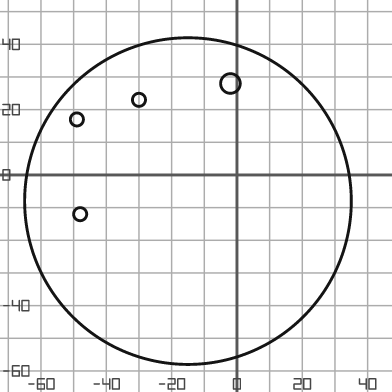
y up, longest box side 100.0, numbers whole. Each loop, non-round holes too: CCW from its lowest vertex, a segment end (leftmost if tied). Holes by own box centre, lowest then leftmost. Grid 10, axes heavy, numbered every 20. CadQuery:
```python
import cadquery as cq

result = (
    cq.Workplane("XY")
    .moveTo(-15.0, -8.0)
    .circle(50.0)
    .moveTo(-48.0, -12.0)
    .circle(2.0)
    .moveTo(-49.0, 17.0)
    .circle(2.0)
    .moveTo(-30.0, 23.0)
    .circle(2.0)
    .moveTo(-2.0, 28.0)
    .circle(3.0)
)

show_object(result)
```